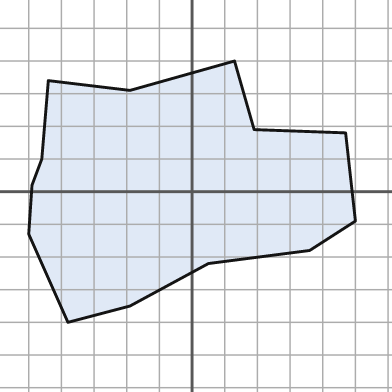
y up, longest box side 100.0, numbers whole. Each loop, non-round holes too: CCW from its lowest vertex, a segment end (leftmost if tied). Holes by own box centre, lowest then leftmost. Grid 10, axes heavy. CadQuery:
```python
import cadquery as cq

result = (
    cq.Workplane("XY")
    .moveTo(-38.0, -40.0)
    .lineTo(-19.0, -35.0)
    .lineTo(5.0, -22.0)
    .lineTo(36.0, -18.0)
    .lineTo(50.0, -9.0)
    .lineTo(47.0, 18.0)
    .lineTo(19.0, 19.0)
    .lineTo(13.0, 40.0)
    .lineTo(-19.0, 31.0)
    .lineTo(-44.0, 34.0)
    .lineTo(-46.0, 10.0)
    .lineTo(-49.0, 2.0)
    .lineTo(-50.0, -13.0)
    .close()
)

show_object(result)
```